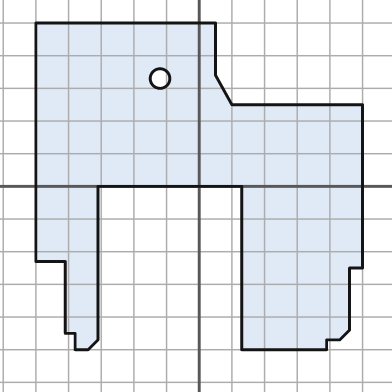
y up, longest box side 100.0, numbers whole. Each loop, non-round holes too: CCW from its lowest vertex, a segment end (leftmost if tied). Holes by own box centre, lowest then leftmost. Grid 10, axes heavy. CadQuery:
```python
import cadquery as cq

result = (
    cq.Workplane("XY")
    .moveTo(-38.0, -50.0)
    .lineTo(-34.0, -50.0)
    .lineTo(-31.0, -47.0)
    .lineTo(-31.0, 0.0)
    .lineTo(13.0, 0.0)
    .lineTo(13.0, -50.0)
    .lineTo(39.0, -50.0)
    .lineTo(39.0, -47.0)
    .lineTo(43.0, -47.0)
    .lineTo(46.0, -44.0)
    .lineTo(46.0, -25.0)
    .lineTo(50.0, -25.0)
    .lineTo(50.0, 25.0)
    .lineTo(10.0, 25.0)
    .lineTo(5.0, 34.0)
    .lineTo(5.0, 50.0)
    .lineTo(-50.0, 50.0)
    .lineTo(-50.0, -23.0)
    .lineTo(-41.0, -23.0)
    .lineTo(-41.0, -45.0)
    .lineTo(-38.0, -45.0)
    .close()
    .moveTo(-12.0, 33.0)
    .circle(3.0)
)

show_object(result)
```